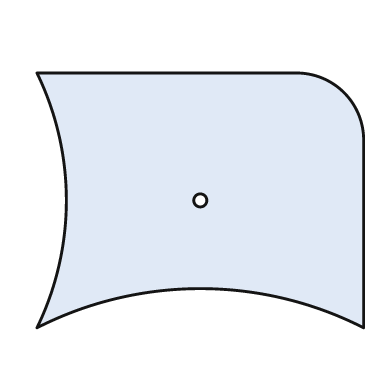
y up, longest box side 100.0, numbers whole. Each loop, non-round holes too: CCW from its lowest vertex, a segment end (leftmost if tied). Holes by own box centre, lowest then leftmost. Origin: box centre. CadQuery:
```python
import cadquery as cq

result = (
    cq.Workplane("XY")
    .moveTo(-50.0, -39.0)
    .threePointArc((0.0, -27.0), (50.0, -39.0))
    .lineTo(50.0, 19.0)
    .threePointArc((44.0, 33.0), (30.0, 39.0))
    .lineTo(-50.0, 39.0)
    .threePointArc((-41.0, 0.0), (-50.0, -39.0))
    .close()
    .moveTo(0.0, 0.0)
    .circle(2.0)
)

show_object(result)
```